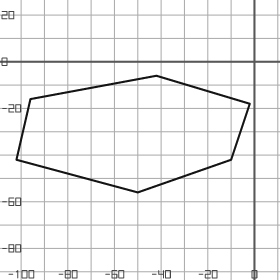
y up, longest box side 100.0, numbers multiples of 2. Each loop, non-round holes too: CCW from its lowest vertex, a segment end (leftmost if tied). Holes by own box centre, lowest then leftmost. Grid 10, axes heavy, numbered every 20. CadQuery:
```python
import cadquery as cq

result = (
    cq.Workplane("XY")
    .moveTo(-50.0, -56.0)
    .lineTo(-10.0, -42.0)
    .lineTo(-2.0, -18.0)
    .lineTo(-42.0, -6.0)
    .lineTo(-96.0, -16.0)
    .lineTo(-102.0, -42.0)
    .close()
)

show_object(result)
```